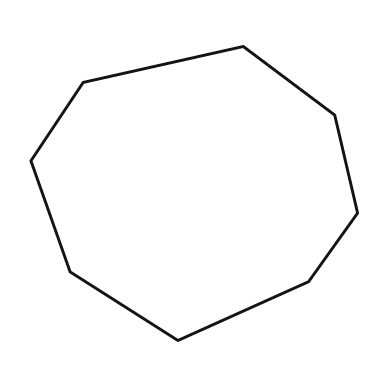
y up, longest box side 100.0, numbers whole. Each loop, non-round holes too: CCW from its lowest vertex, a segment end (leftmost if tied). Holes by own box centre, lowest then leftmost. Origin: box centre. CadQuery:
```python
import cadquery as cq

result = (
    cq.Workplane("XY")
    .moveTo(-5.0, -45.0)
    .lineTo(35.0, -27.0)
    .lineTo(50.0, -6.0)
    .lineTo(43.0, 24.0)
    .lineTo(15.0, 45.0)
    .lineTo(-34.0, 34.0)
    .lineTo(-50.0, 10.0)
    .lineTo(-38.0, -24.0)
    .close()
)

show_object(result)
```